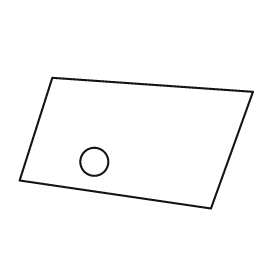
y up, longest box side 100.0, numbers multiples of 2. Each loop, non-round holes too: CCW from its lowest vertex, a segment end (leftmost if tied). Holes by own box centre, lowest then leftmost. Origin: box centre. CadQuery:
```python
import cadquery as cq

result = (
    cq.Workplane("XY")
    .moveTo(32.0, -28.0)
    .lineTo(50.0, 22.0)
    .lineTo(-36.0, 28.0)
    .lineTo(-50.0, -16.0)
    .close()
    .moveTo(-18.0, -8.0)
    .circle(6.0)
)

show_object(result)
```